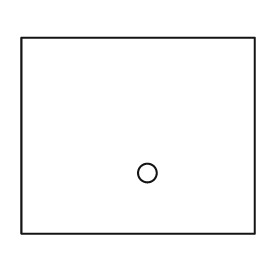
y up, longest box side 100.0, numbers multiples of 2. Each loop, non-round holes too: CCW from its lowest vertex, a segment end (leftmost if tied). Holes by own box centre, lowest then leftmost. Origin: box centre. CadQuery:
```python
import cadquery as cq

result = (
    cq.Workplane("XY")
    .moveTo(-50.0, -42.0)
    .lineTo(50.0, -42.0)
    .lineTo(50.0, 42.0)
    .lineTo(-50.0, 42.0)
    .close()
    .moveTo(4.0, -16.0)
    .circle(4.0)
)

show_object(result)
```